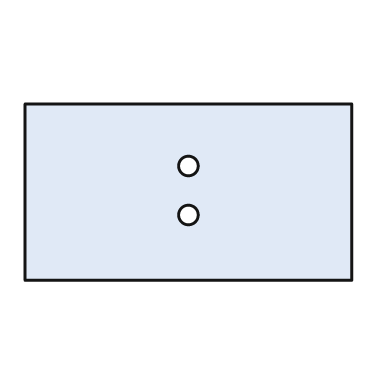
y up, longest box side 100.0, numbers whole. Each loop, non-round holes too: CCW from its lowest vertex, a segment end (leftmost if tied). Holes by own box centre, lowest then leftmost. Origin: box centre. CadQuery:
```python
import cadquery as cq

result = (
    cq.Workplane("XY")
    .moveTo(-50.0, -27.0)
    .lineTo(50.0, -27.0)
    .lineTo(50.0, 27.0)
    .lineTo(-50.0, 27.0)
    .close()
    .moveTo(0.0, -7.0)
    .circle(3.0)
    .moveTo(0.0, 8.0)
    .circle(3.0)
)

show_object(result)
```